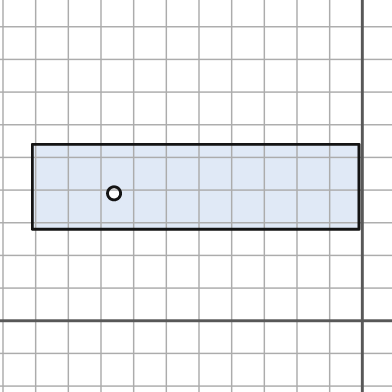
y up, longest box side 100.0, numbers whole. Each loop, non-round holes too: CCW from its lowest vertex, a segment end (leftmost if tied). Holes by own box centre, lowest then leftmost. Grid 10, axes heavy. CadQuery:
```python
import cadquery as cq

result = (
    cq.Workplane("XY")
    .moveTo(-101.0, 28.0)
    .lineTo(-1.0, 28.0)
    .lineTo(-1.0, 54.0)
    .lineTo(-101.0, 54.0)
    .close()
    .moveTo(-76.0, 39.0)
    .circle(2.0)
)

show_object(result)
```